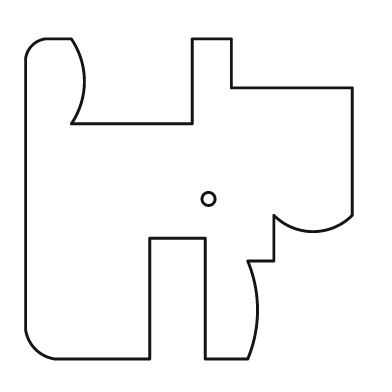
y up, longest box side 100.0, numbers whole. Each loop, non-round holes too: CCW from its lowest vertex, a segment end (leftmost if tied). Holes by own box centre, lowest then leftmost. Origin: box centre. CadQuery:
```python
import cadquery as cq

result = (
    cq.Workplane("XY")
    .moveTo(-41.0, -49.0)
    .lineTo(-12.0, -49.0)
    .lineTo(-12.0, -12.0)
    .lineTo(5.0, -12.0)
    .lineTo(5.0, -49.0)
    .lineTo(18.0, -49.0)
    .threePointArc((21.0, -34.0), (18.0, -19.0))
    .lineTo(26.0, -19.0)
    .lineTo(26.0, -5.0)
    .threePointArc((38.0, -10.0), (50.0, -5.0))
    .lineTo(50.0, 34.0)
    .lineTo(13.0, 34.0)
    .lineTo(13.0, 49.0)
    .lineTo(1.0, 49.0)
    .lineTo(1.0, 23.0)
    .lineTo(-36.0, 23.0)
    .threePointArc((-32.0, 36.0), (-36.0, 49.0))
    .lineTo(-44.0, 49.0)
    .threePointArc((-48.0, 47.0), (-50.0, 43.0))
    .lineTo(-50.0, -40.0)
    .threePointArc((-47.0, -46.0), (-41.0, -49.0))
    .close()
    .moveTo(6.0, 0.0)
    .circle(2.0)
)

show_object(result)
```